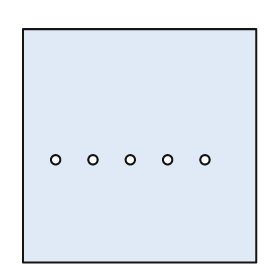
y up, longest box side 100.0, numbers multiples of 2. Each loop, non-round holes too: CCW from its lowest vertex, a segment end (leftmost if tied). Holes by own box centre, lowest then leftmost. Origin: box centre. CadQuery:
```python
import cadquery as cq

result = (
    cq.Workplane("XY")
    .moveTo(-50.0, -50.0)
    .lineTo(50.0, -50.0)
    .lineTo(50.0, 50.0)
    .lineTo(-50.0, 50.0)
    .close()
    .moveTo(-36.0, -6.0)
    .circle(2.0)
    .moveTo(-20.0, -6.0)
    .circle(2.0)
    .moveTo(-4.0, -6.0)
    .circle(2.0)
    .moveTo(12.0, -6.0)
    .circle(2.0)
    .moveTo(28.0, -6.0)
    .circle(2.0)
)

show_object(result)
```